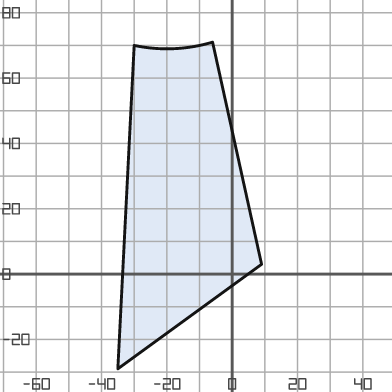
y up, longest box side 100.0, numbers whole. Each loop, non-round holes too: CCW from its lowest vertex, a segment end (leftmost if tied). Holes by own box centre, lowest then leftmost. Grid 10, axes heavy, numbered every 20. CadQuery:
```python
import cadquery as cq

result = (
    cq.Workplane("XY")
    .moveTo(-35.0, -29.0)
    .lineTo(9.0, 3.0)
    .lineTo(-6.0, 71.0)
    .threePointArc((-18.0, 69.0), (-30.0, 70.0))
    .close()
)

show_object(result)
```